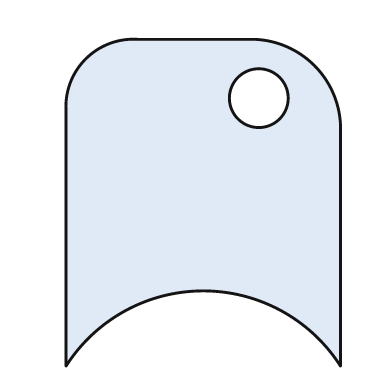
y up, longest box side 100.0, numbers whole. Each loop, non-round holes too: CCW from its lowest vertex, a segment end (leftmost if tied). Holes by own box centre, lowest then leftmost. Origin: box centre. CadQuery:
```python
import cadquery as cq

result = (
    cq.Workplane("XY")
    .moveTo(-42.0, -50.0)
    .threePointArc((0.0, -27.0), (42.0, -50.0))
    .lineTo(42.0, 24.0)
    .threePointArc((34.0, 42.0), (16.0, 50.0))
    .lineTo(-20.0, 50.0)
    .threePointArc((-36.0, 44.0), (-42.0, 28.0))
    .close()
    .moveTo(17.0, 32.0)
    .circle(9.0)
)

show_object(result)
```